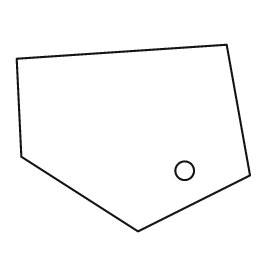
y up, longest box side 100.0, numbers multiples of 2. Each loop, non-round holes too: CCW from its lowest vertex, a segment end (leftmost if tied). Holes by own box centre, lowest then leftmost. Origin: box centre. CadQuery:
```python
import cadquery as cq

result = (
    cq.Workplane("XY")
    .moveTo(2.0, -40.0)
    .lineTo(50.0, -16.0)
    .lineTo(40.0, 40.0)
    .lineTo(-50.0, 34.0)
    .lineTo(-48.0, -8.0)
    .close()
    .moveTo(22.0, -14.0)
    .circle(4.0)
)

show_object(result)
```